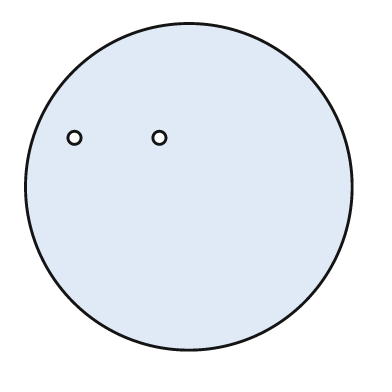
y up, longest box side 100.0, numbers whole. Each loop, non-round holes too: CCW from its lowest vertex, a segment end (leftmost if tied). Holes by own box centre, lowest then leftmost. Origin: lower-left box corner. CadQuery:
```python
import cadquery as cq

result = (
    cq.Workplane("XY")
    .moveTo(50.0, 50.0)
    .circle(50.0)
    .moveTo(15.0, 65.0)
    .circle(2.0)
    .moveTo(41.0, 65.0)
    .circle(2.0)
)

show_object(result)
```